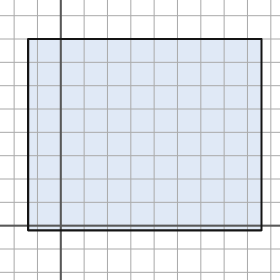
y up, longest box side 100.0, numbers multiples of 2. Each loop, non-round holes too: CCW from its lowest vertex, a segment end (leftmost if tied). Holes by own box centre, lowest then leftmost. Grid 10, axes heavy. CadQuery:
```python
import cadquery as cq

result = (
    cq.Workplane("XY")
    .moveTo(-14.0, -2.0)
    .lineTo(86.0, -2.0)
    .lineTo(86.0, 80.0)
    .lineTo(-14.0, 80.0)
    .close()
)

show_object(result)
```